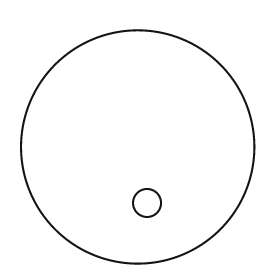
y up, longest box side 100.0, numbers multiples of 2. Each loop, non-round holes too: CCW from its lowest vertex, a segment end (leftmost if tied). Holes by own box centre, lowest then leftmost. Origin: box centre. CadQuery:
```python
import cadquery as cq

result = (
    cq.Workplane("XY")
    .moveTo(0.0, 0.0)
    .circle(50.0)
    .moveTo(4.0, -24.0)
    .circle(6.0)
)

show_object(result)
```